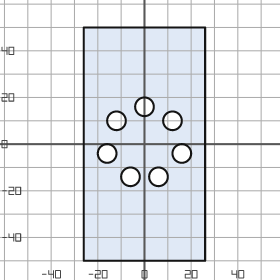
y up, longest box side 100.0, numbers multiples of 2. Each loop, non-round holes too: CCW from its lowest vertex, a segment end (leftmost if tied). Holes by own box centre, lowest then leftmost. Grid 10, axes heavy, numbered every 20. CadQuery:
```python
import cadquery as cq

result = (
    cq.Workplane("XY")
    .moveTo(-26.0, -50.0)
    .lineTo(26.0, -50.0)
    .lineTo(26.0, 50.0)
    .lineTo(-26.0, 50.0)
    .close()
    .moveTo(-6.0, -14.0)
    .circle(4.0)
    .moveTo(6.0, -14.0)
    .circle(4.0)
    .moveTo(-16.0, -4.0)
    .circle(4.0)
    .moveTo(16.0, -4.0)
    .circle(4.0)
    .moveTo(-12.0, 10.0)
    .circle(4.0)
    .moveTo(12.0, 10.0)
    .circle(4.0)
    .moveTo(0.0, 16.0)
    .circle(4.0)
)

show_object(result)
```